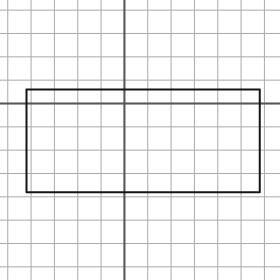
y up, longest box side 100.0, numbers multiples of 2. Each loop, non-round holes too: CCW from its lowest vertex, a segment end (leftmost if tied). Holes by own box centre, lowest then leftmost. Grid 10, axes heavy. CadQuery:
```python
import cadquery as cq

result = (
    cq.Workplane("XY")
    .moveTo(-42.0, -38.0)
    .lineTo(58.0, -38.0)
    .lineTo(58.0, 6.0)
    .lineTo(-42.0, 6.0)
    .close()
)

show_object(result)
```